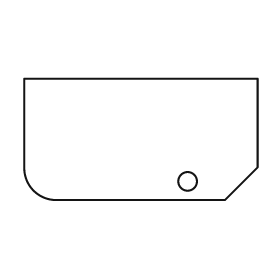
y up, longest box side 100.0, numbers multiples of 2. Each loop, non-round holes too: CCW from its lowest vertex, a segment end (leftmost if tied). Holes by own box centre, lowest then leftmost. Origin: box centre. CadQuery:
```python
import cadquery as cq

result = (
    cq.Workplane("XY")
    .moveTo(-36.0, -26.0)
    .lineTo(36.0, -26.0)
    .lineTo(50.0, -12.0)
    .lineTo(50.0, 26.0)
    .lineTo(-50.0, 26.0)
    .lineTo(-50.0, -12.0)
    .threePointArc((-46.0, -22.0), (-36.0, -26.0))
    .close()
    .moveTo(20.0, -18.0)
    .circle(4.0)
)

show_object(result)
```